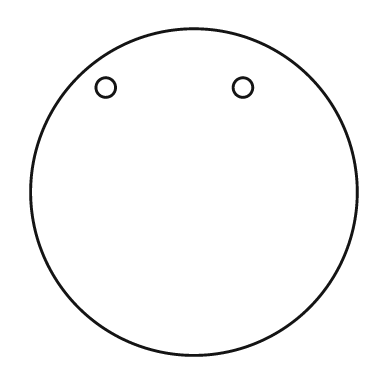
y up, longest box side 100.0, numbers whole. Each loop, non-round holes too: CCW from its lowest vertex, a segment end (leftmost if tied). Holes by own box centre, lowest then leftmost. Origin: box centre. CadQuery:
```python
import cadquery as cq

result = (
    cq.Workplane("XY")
    .moveTo(0.0, 0.0)
    .circle(50.0)
    .moveTo(-27.0, 32.0)
    .circle(3.0)
    .moveTo(15.0, 32.0)
    .circle(3.0)
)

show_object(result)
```